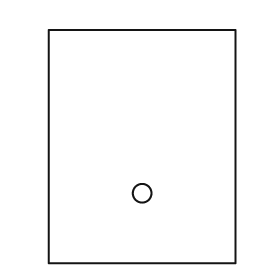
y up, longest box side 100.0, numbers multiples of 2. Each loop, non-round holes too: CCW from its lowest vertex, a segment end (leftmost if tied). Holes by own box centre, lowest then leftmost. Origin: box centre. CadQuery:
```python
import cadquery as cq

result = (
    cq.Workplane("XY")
    .moveTo(-40.0, -50.0)
    .lineTo(40.0, -50.0)
    .lineTo(40.0, 50.0)
    .lineTo(-40.0, 50.0)
    .close()
    .moveTo(0.0, -20.0)
    .circle(4.0)
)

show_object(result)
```